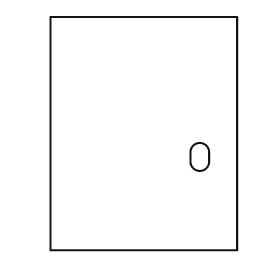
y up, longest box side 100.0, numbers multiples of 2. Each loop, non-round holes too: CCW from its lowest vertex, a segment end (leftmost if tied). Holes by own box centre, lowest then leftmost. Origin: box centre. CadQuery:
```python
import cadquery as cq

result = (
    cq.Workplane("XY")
    .moveTo(-40.0, -50.0)
    .lineTo(40.0, -50.0)
    .lineTo(40.0, 50.0)
    .lineTo(-40.0, 50.0)
    .close()
    .moveTo(20.0, -12.0)
    .threePointArc((24.0, -16.0), (28.0, -12.0))
    .lineTo(28.0, -8.0)
    .threePointArc((24.0, -4.0), (20.0, -8.0))
    .close()
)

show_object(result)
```